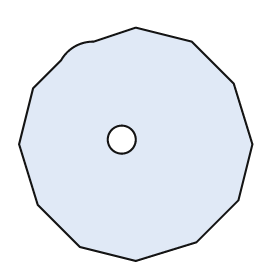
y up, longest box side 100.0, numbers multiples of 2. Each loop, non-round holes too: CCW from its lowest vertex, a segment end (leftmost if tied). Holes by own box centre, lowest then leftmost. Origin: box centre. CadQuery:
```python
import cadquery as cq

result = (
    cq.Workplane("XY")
    .moveTo(0.0, -50.0)
    .lineTo(26.0, -42.0)
    .lineTo(44.0, -24.0)
    .lineTo(50.0, 0.0)
    .lineTo(42.0, 26.0)
    .lineTo(24.0, 44.0)
    .lineTo(0.0, 50.0)
    .lineTo(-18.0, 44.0)
    .threePointArc((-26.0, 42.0), (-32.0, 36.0))
    .lineTo(-44.0, 24.0)
    .lineTo(-50.0, 0.0)
    .lineTo(-42.0, -26.0)
    .lineTo(-24.0, -44.0)
    .close()
    .moveTo(-6.0, 2.0)
    .circle(6.0)
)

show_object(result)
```